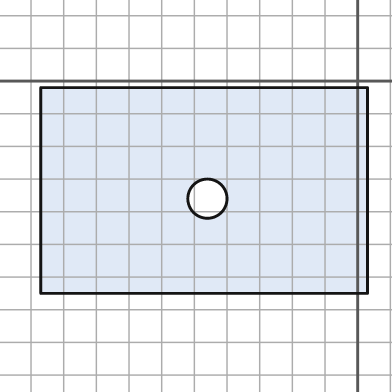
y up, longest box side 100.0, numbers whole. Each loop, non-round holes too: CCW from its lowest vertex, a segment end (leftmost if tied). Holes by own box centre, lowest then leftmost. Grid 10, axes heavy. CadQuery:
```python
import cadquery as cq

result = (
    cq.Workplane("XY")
    .moveTo(-97.0, -65.0)
    .lineTo(3.0, -65.0)
    .lineTo(3.0, -2.0)
    .lineTo(-97.0, -2.0)
    .close()
    .moveTo(-46.0, -36.0)
    .circle(6.0)
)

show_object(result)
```